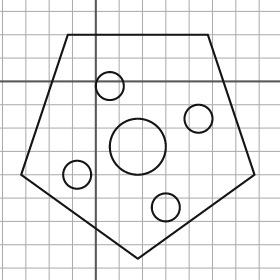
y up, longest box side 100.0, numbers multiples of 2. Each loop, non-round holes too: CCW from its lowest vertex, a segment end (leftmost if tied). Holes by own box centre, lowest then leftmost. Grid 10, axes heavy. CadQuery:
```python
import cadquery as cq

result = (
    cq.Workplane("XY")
    .moveTo(18.0, -76.0)
    .lineTo(68.0, -40.0)
    .lineTo(48.0, 20.0)
    .lineTo(-12.0, 20.0)
    .lineTo(-32.0, -40.0)
    .close()
    .moveTo(30.0, -54.0)
    .circle(6.0)
    .moveTo(-8.0, -40.0)
    .circle(6.0)
    .moveTo(18.0, -28.0)
    .circle(12.0)
    .moveTo(44.0, -16.0)
    .circle(6.0)
    .moveTo(6.0, -2.0)
    .circle(6.0)
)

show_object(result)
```